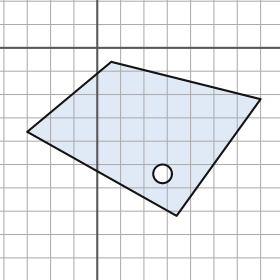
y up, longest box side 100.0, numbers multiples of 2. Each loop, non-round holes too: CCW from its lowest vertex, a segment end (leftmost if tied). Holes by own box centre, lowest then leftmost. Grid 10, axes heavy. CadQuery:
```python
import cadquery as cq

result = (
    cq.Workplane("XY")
    .moveTo(34.0, -72.0)
    .lineTo(70.0, -22.0)
    .lineTo(6.0, -6.0)
    .lineTo(-30.0, -36.0)
    .close()
    .moveTo(28.0, -54.0)
    .circle(4.0)
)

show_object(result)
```